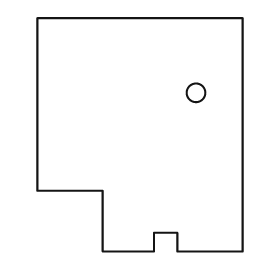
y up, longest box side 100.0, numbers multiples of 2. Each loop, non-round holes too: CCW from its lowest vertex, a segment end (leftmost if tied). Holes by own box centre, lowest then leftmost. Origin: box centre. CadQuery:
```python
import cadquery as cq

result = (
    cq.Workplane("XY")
    .moveTo(-16.0, -50.0)
    .lineTo(6.0, -50.0)
    .lineTo(6.0, -42.0)
    .lineTo(16.0, -42.0)
    .lineTo(16.0, -50.0)
    .lineTo(44.0, -50.0)
    .lineTo(44.0, 50.0)
    .lineTo(-44.0, 50.0)
    .lineTo(-44.0, -24.0)
    .lineTo(-16.0, -24.0)
    .close()
    .moveTo(24.0, 18.0)
    .circle(4.0)
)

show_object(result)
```